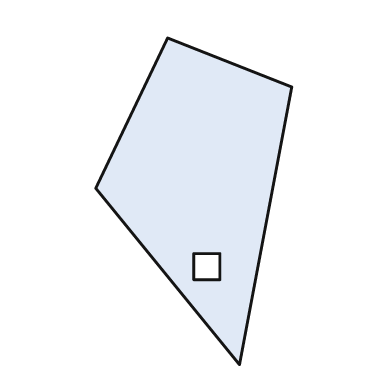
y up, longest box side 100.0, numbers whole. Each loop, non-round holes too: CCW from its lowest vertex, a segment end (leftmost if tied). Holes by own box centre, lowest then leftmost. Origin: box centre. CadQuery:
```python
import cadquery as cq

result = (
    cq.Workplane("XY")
    .moveTo(14.0, -50.0)
    .lineTo(30.0, 35.0)
    .lineTo(-8.0, 50.0)
    .lineTo(-30.0, 4.0)
    .close()
    .moveTo(0.0, -24.0)
    .lineTo(8.0, -24.0)
    .lineTo(8.0, -16.0)
    .lineTo(0.0, -16.0)
    .close()
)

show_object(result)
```